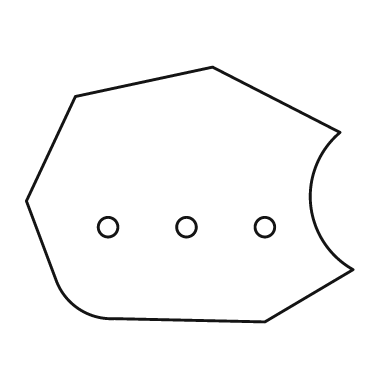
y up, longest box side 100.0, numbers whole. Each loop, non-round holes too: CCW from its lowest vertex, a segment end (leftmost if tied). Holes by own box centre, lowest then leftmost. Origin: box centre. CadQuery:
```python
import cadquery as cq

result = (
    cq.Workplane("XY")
    .moveTo(23.0, -39.0)
    .lineTo(50.0, -23.0)
    .threePointArc((37.0, -3.0), (46.0, 19.0))
    .lineTo(7.0, 39.0)
    .lineTo(-35.0, 30.0)
    .lineTo(-50.0, -2.0)
    .lineTo(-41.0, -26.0)
    .threePointArc((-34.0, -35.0), (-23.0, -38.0))
    .close()
    .moveTo(-25.0, -10.0)
    .circle(3.0)
    .moveTo(-1.0, -10.0)
    .circle(3.0)
    .moveTo(23.0, -10.0)
    .circle(3.0)
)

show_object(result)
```